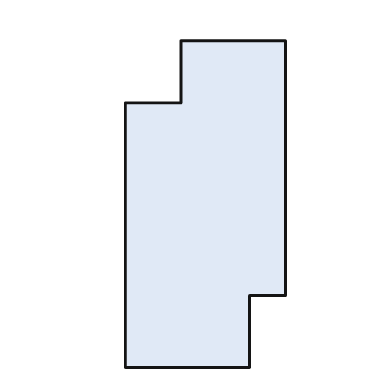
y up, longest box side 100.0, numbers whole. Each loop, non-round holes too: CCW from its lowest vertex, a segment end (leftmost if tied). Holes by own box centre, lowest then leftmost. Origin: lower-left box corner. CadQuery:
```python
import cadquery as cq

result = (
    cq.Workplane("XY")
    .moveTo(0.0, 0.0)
    .lineTo(38.0, 0.0)
    .lineTo(38.0, 22.0)
    .lineTo(49.0, 22.0)
    .lineTo(49.0, 100.0)
    .lineTo(17.0, 100.0)
    .lineTo(17.0, 81.0)
    .lineTo(0.0, 81.0)
    .close()
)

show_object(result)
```